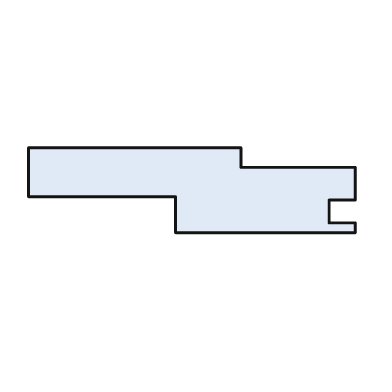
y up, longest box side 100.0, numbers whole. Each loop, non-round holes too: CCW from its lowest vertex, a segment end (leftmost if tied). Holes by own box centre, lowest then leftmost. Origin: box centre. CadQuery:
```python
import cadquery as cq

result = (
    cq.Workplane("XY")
    .moveTo(-5.0, -13.0)
    .lineTo(50.0, -13.0)
    .lineTo(50.0, -10.0)
    .lineTo(42.0, -10.0)
    .lineTo(42.0, -3.0)
    .lineTo(50.0, -3.0)
    .lineTo(50.0, 7.0)
    .lineTo(15.0, 7.0)
    .lineTo(15.0, 13.0)
    .lineTo(-50.0, 13.0)
    .lineTo(-50.0, -2.0)
    .lineTo(-5.0, -2.0)
    .close()
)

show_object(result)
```